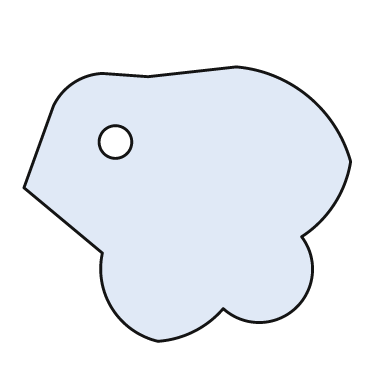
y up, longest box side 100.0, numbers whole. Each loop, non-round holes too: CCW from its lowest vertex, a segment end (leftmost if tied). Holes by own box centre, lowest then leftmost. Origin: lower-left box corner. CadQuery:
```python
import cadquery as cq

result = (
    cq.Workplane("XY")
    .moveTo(41.0, 0.0)
    .threePointArc((52.0, 3.0), (61.0, 10.0))
    .threePointArc((83.0, 10.0), (85.0, 32.0))
    .threePointArc((95.0, 42.0), (100.0, 55.0))
    .threePointArc((87.0, 75.0), (65.0, 84.0))
    .lineTo(38.0, 81.0)
    .lineTo(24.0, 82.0)
    .threePointArc((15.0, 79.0), (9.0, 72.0))
    .lineTo(0.0, 47.0)
    .lineTo(24.0, 27.0)
    .threePointArc((27.0, 10.0), (41.0, 0.0))
    .close()
    .moveTo(28.0, 61.0)
    .circle(5.0)
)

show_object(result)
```